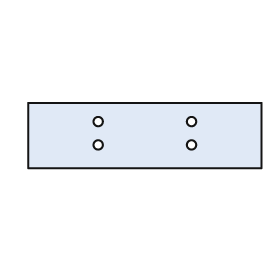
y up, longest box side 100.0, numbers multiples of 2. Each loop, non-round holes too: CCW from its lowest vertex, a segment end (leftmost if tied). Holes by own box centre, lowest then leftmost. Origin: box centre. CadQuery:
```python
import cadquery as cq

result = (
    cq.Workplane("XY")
    .moveTo(-50.0, -14.0)
    .lineTo(50.0, -14.0)
    .lineTo(50.0, 14.0)
    .lineTo(-50.0, 14.0)
    .close()
    .moveTo(-20.0, -4.0)
    .circle(2.0)
    .moveTo(20.0, -4.0)
    .circle(2.0)
    .moveTo(-20.0, 6.0)
    .circle(2.0)
    .moveTo(20.0, 6.0)
    .circle(2.0)
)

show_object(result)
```